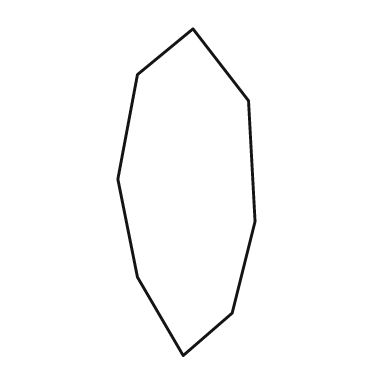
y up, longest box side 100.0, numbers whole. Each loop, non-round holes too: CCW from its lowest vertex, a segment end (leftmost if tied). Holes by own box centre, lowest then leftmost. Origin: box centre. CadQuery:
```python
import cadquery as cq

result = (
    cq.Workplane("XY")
    .moveTo(-1.0, -50.0)
    .lineTo(14.0, -37.0)
    .lineTo(21.0, -9.0)
    .lineTo(19.0, 28.0)
    .lineTo(2.0, 50.0)
    .lineTo(-15.0, 36.0)
    .lineTo(-21.0, 4.0)
    .lineTo(-15.0, -26.0)
    .close()
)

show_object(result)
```